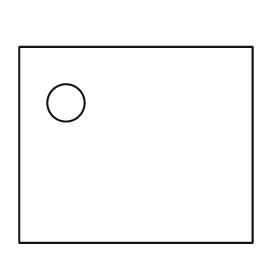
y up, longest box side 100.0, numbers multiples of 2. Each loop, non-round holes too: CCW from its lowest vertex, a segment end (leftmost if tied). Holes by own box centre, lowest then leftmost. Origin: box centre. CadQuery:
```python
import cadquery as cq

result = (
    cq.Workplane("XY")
    .moveTo(-50.0, -42.0)
    .lineTo(50.0, -42.0)
    .lineTo(50.0, 42.0)
    .lineTo(-50.0, 42.0)
    .close()
    .moveTo(-30.0, 18.0)
    .circle(8.0)
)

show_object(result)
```